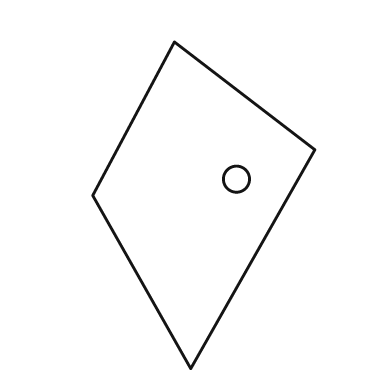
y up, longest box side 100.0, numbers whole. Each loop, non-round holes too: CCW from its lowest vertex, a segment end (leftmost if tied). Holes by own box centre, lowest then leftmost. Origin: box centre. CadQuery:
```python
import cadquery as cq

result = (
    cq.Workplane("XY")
    .moveTo(-4.0, -50.0)
    .lineTo(34.0, 17.0)
    .lineTo(-9.0, 50.0)
    .lineTo(-34.0, 3.0)
    .close()
    .moveTo(10.0, 8.0)
    .circle(4.0)
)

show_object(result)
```